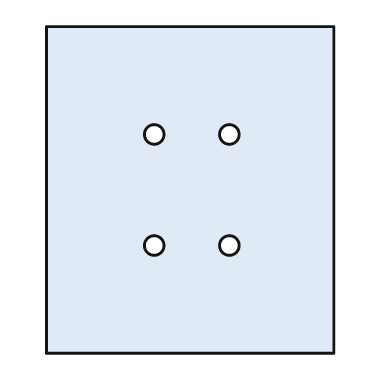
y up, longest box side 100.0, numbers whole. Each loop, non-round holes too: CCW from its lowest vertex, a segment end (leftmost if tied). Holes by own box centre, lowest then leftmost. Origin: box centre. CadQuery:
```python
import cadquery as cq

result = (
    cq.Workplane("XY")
    .moveTo(-44.0, -50.0)
    .lineTo(44.0, -50.0)
    .lineTo(44.0, 50.0)
    .lineTo(-44.0, 50.0)
    .close()
    .moveTo(-11.0, -17.0)
    .circle(3.0)
    .moveTo(12.0, -17.0)
    .circle(3.0)
    .moveTo(-11.0, 17.0)
    .circle(3.0)
    .moveTo(12.0, 17.0)
    .circle(3.0)
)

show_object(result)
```